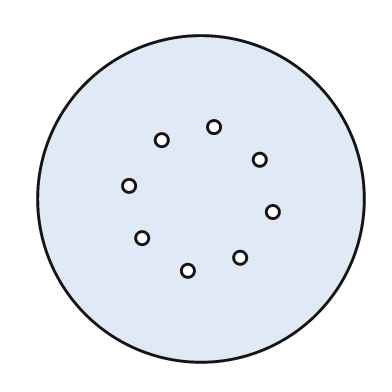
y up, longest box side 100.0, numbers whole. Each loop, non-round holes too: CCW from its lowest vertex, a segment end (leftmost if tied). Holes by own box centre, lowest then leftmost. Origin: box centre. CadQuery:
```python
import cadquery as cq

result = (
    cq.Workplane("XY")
    .moveTo(0.0, 0.0)
    .circle(50.0)
    .moveTo(-4.0, -22.0)
    .circle(2.0)
    .moveTo(12.0, -18.0)
    .circle(2.0)
    .moveTo(-18.0, -12.0)
    .circle(2.0)
    .moveTo(22.0, -4.0)
    .circle(2.0)
    .moveTo(-22.0, 4.0)
    .circle(2.0)
    .moveTo(18.0, 12.0)
    .circle(2.0)
    .moveTo(-12.0, 18.0)
    .circle(2.0)
    .moveTo(4.0, 22.0)
    .circle(2.0)
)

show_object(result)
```